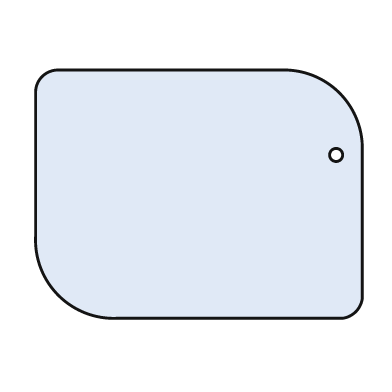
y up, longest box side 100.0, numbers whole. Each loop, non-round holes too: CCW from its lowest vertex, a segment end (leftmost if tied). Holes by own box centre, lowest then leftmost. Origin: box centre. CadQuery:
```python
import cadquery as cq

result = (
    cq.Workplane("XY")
    .moveTo(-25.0, -38.0)
    .lineTo(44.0, -38.0)
    .threePointArc((48.0, -36.0), (50.0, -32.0))
    .lineTo(50.0, 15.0)
    .threePointArc((43.0, 31.0), (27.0, 38.0))
    .lineTo(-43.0, 38.0)
    .threePointArc((-48.0, 36.0), (-50.0, 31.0))
    .lineTo(-50.0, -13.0)
    .threePointArc((-43.0, -31.0), (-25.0, -38.0))
    .close()
    .moveTo(42.0, 12.0)
    .circle(2.0)
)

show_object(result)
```